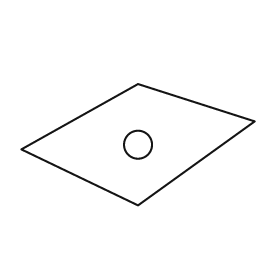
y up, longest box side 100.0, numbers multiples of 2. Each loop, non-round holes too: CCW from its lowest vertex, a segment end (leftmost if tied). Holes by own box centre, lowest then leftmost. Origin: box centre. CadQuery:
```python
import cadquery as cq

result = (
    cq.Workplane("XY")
    .moveTo(0.0, -26.0)
    .lineTo(50.0, 10.0)
    .lineTo(0.0, 26.0)
    .lineTo(-50.0, -2.0)
    .close()
    .moveTo(0.0, 0.0)
    .circle(6.0)
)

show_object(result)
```